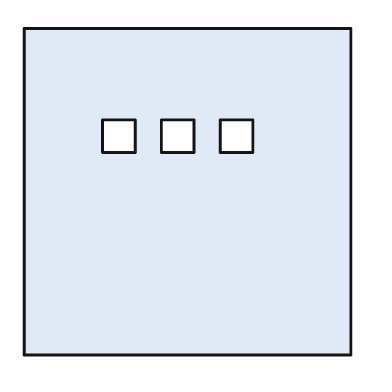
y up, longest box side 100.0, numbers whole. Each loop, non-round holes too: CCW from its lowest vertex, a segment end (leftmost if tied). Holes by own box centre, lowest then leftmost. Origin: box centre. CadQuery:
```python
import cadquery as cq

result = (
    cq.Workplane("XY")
    .moveTo(-50.0, -50.0)
    .lineTo(50.0, -50.0)
    .lineTo(50.0, 50.0)
    .lineTo(-50.0, 50.0)
    .close()
    .moveTo(-26.0, 12.0)
    .lineTo(-16.0, 12.0)
    .lineTo(-16.0, 22.0)
    .lineTo(-26.0, 22.0)
    .close()
    .moveTo(-8.0, 12.0)
    .lineTo(2.0, 12.0)
    .lineTo(2.0, 22.0)
    .lineTo(-8.0, 22.0)
    .close()
    .moveTo(10.0, 12.0)
    .lineTo(20.0, 12.0)
    .lineTo(20.0, 22.0)
    .lineTo(10.0, 22.0)
    .close()
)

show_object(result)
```